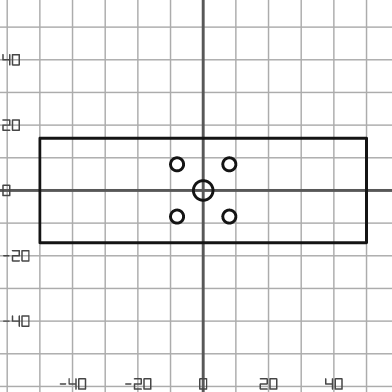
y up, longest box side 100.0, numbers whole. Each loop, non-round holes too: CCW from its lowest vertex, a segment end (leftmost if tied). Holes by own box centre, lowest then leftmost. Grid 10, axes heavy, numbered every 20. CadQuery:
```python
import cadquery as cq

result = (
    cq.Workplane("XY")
    .moveTo(-50.0, -16.0)
    .lineTo(50.0, -16.0)
    .lineTo(50.0, 16.0)
    .lineTo(-50.0, 16.0)
    .close()
    .moveTo(-8.0, -8.0)
    .circle(2.0)
    .moveTo(8.0, -8.0)
    .circle(2.0)
    .moveTo(0.0, 0.0)
    .circle(3.0)
    .moveTo(-8.0, 8.0)
    .circle(2.0)
    .moveTo(8.0, 8.0)
    .circle(2.0)
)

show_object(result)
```